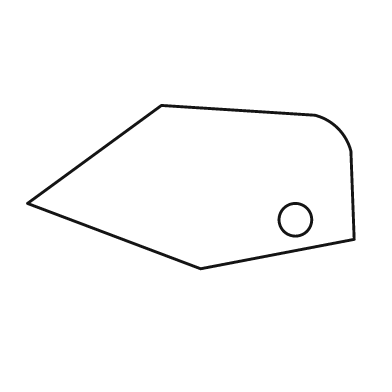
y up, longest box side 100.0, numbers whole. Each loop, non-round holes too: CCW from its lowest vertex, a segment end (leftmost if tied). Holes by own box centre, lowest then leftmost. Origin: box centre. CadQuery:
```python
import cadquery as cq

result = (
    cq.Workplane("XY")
    .moveTo(3.0, -25.0)
    .lineTo(50.0, -16.0)
    .lineTo(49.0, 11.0)
    .threePointArc((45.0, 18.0), (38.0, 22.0))
    .lineTo(-9.0, 25.0)
    .lineTo(-50.0, -5.0)
    .close()
    .moveTo(32.0, -10.0)
    .circle(5.0)
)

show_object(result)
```